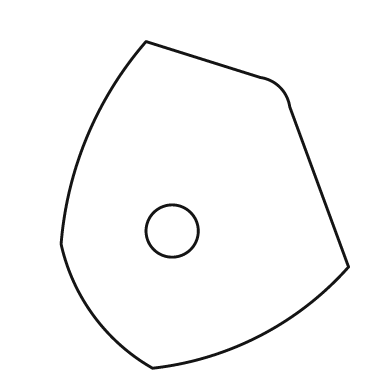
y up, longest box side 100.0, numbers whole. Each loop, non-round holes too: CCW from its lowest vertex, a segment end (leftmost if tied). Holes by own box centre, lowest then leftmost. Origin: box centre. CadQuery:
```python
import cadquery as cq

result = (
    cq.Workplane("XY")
    .moveTo(-16.0, -50.0)
    .threePointArc((17.0, -40.0), (44.0, -19.0))
    .lineTo(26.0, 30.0)
    .threePointArc((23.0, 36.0), (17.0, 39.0))
    .lineTo(-18.0, 50.0)
    .threePointArc((-36.0, 21.0), (-44.0, -12.0))
    .threePointArc((-34.0, -34.0), (-16.0, -50.0))
    .close()
    .moveTo(-10.0, -8.0)
    .circle(8.0)
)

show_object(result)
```